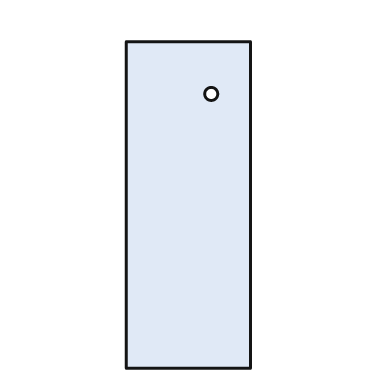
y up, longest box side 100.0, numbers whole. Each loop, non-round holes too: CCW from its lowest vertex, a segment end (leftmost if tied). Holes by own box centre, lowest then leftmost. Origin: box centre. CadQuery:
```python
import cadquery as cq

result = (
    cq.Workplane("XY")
    .moveTo(-19.0, -50.0)
    .lineTo(19.0, -50.0)
    .lineTo(19.0, 50.0)
    .lineTo(-19.0, 50.0)
    .close()
    .moveTo(7.0, 34.0)
    .circle(2.0)
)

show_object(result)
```